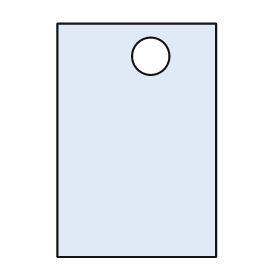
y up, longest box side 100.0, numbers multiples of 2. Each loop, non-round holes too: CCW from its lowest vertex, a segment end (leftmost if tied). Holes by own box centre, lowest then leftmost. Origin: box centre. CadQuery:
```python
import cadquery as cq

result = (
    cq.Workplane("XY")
    .moveTo(-34.0, -50.0)
    .lineTo(34.0, -50.0)
    .lineTo(34.0, 50.0)
    .lineTo(-34.0, 50.0)
    .close()
    .moveTo(6.0, 36.0)
    .circle(8.0)
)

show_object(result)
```